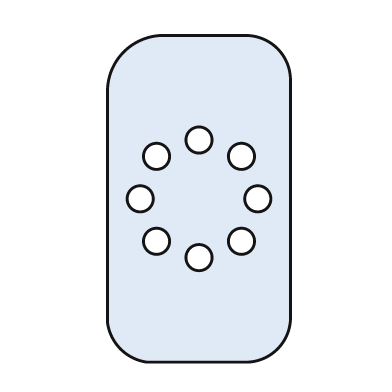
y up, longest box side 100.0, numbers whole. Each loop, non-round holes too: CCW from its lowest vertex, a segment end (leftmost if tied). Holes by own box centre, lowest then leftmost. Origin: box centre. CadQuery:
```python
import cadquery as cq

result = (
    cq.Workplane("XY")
    .moveTo(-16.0, -50.0)
    .lineTo(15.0, -50.0)
    .threePointArc((24.0, -46.0), (28.0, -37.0))
    .lineTo(28.0, 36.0)
    .threePointArc((24.0, 46.0), (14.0, 50.0))
    .lineTo(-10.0, 50.0)
    .threePointArc((-23.0, 45.0), (-28.0, 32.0))
    .lineTo(-28.0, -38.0)
    .threePointArc((-24.0, -46.0), (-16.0, -50.0))
    .close()
    .moveTo(0.0, -18.0)
    .circle(4.0)
    .moveTo(-13.0, -13.0)
    .circle(4.0)
    .moveTo(13.0, -13.0)
    .circle(4.0)
    .moveTo(-18.0, 0.0)
    .circle(4.0)
    .moveTo(18.0, 0.0)
    .circle(4.0)
    .moveTo(-13.0, 13.0)
    .circle(4.0)
    .moveTo(13.0, 13.0)
    .circle(4.0)
    .moveTo(0.0, 18.0)
    .circle(4.0)
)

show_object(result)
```